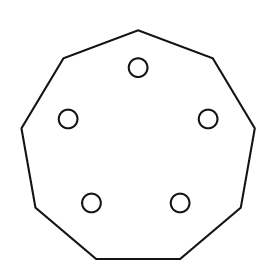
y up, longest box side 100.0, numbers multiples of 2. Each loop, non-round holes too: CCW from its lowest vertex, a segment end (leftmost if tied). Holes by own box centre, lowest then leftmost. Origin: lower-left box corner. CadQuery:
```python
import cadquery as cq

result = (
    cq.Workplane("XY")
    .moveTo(32.0, 0.0)
    .lineTo(68.0, 0.0)
    .lineTo(94.0, 22.0)
    .lineTo(100.0, 56.0)
    .lineTo(82.0, 86.0)
    .lineTo(50.0, 98.0)
    .lineTo(18.0, 86.0)
    .lineTo(0.0, 56.0)
    .lineTo(6.0, 22.0)
    .close()
    .moveTo(30.0, 24.0)
    .circle(4.0)
    .moveTo(68.0, 24.0)
    .circle(4.0)
    .moveTo(20.0, 60.0)
    .circle(4.0)
    .moveTo(80.0, 60.0)
    .circle(4.0)
    .moveTo(50.0, 82.0)
    .circle(4.0)
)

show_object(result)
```